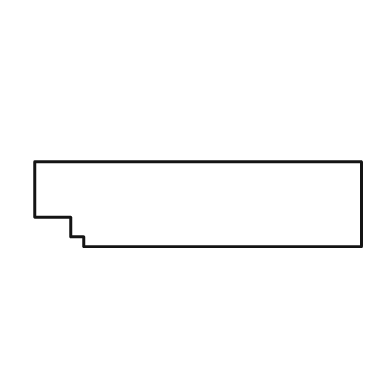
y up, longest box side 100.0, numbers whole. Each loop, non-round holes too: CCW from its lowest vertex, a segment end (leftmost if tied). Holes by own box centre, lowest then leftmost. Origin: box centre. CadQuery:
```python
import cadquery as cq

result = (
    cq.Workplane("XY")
    .moveTo(-35.0, -13.0)
    .lineTo(50.0, -13.0)
    .lineTo(50.0, 13.0)
    .lineTo(-50.0, 13.0)
    .lineTo(-50.0, -4.0)
    .lineTo(-39.0, -4.0)
    .lineTo(-39.0, -10.0)
    .lineTo(-35.0, -10.0)
    .close()
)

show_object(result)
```